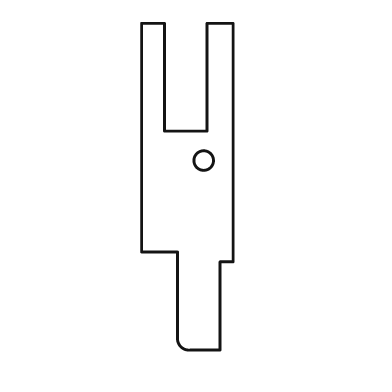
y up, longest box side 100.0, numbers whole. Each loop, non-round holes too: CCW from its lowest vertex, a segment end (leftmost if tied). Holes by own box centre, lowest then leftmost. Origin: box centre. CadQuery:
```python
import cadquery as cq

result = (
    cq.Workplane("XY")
    .moveTo(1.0, -50.0)
    .lineTo(10.0, -50.0)
    .lineTo(10.0, -23.0)
    .lineTo(14.0, -23.0)
    .lineTo(14.0, 50.0)
    .lineTo(6.0, 50.0)
    .lineTo(6.0, 17.0)
    .lineTo(-7.0, 17.0)
    .lineTo(-7.0, 50.0)
    .lineTo(-14.0, 50.0)
    .lineTo(-14.0, -20.0)
    .lineTo(-3.0, -20.0)
    .lineTo(-3.0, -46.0)
    .threePointArc((-2.0, -49.0), (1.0, -50.0))
    .close()
    .moveTo(5.0, 8.0)
    .circle(3.0)
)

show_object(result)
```